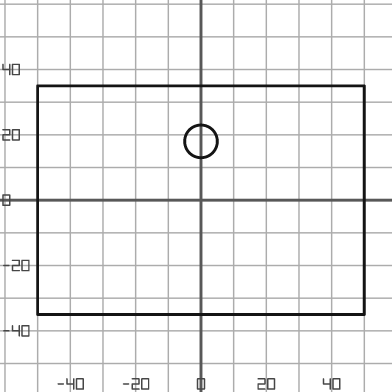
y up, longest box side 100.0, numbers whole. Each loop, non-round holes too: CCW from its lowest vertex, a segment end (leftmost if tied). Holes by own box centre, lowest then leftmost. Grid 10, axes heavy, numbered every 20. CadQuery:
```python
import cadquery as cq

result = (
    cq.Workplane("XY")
    .moveTo(-50.0, -35.0)
    .lineTo(50.0, -35.0)
    .lineTo(50.0, 35.0)
    .lineTo(-50.0, 35.0)
    .close()
    .moveTo(0.0, 18.0)
    .circle(5.0)
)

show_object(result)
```